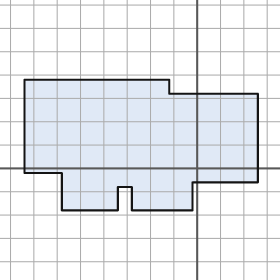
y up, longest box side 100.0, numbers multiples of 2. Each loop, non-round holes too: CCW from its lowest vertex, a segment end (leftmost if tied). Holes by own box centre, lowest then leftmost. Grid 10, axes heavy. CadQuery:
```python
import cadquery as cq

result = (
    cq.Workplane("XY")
    .moveTo(-58.0, -18.0)
    .lineTo(-34.0, -18.0)
    .lineTo(-34.0, -8.0)
    .lineTo(-28.0, -8.0)
    .lineTo(-28.0, -18.0)
    .lineTo(-2.0, -18.0)
    .lineTo(-2.0, -6.0)
    .lineTo(26.0, -6.0)
    .lineTo(26.0, 32.0)
    .lineTo(-12.0, 32.0)
    .lineTo(-12.0, 38.0)
    .lineTo(-74.0, 38.0)
    .lineTo(-74.0, -2.0)
    .lineTo(-58.0, -2.0)
    .close()
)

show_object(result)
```